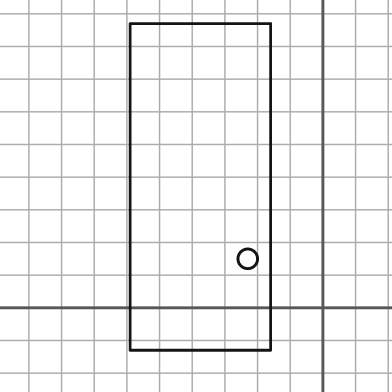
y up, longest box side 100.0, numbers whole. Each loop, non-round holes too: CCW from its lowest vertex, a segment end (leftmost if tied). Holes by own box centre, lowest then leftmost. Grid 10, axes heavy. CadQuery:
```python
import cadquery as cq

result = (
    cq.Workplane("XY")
    .moveTo(-59.0, -13.0)
    .lineTo(-16.0, -13.0)
    .lineTo(-16.0, 87.0)
    .lineTo(-59.0, 87.0)
    .close()
    .moveTo(-23.0, 15.0)
    .circle(3.0)
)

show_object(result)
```